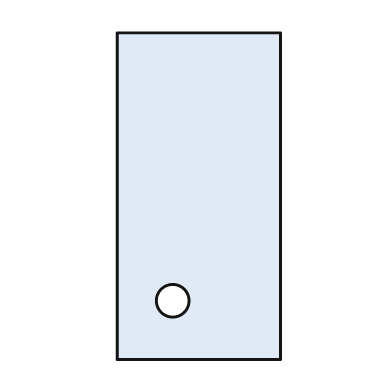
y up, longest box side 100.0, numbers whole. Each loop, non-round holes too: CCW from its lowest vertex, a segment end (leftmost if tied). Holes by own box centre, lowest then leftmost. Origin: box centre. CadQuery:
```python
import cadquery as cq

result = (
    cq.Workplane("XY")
    .moveTo(-25.0, -50.0)
    .lineTo(25.0, -50.0)
    .lineTo(25.0, 50.0)
    .lineTo(-25.0, 50.0)
    .close()
    .moveTo(-8.0, -32.0)
    .circle(5.0)
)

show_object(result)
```